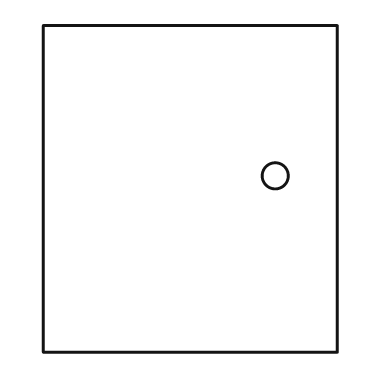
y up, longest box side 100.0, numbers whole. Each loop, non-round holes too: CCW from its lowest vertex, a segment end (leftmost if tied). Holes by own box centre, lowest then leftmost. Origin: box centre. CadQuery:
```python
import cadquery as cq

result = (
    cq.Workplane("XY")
    .moveTo(-45.0, -50.0)
    .lineTo(45.0, -50.0)
    .lineTo(45.0, 50.0)
    .lineTo(-45.0, 50.0)
    .close()
    .moveTo(26.0, 4.0)
    .circle(4.0)
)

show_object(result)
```